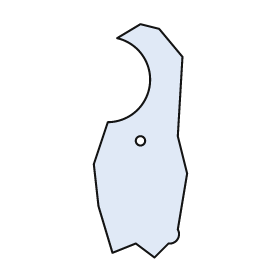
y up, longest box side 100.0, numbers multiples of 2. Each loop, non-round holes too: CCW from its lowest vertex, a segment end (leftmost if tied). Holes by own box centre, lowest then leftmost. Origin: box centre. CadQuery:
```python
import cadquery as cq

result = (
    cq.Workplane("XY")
    .moveTo(6.0, -50.0)
    .lineTo(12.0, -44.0)
    .threePointArc((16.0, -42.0), (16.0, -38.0))
    .lineTo(20.0, -14.0)
    .lineTo(16.0, 2.0)
    .lineTo(18.0, 36.0)
    .lineTo(8.0, 48.0)
    .lineTo(0.0, 50.0)
    .lineTo(-10.0, 44.0)
    .threePointArc((4.0, 24.0), (-14.0, 8.0))
    .lineTo(-20.0, -10.0)
    .lineTo(-18.0, -28.0)
    .lineTo(-12.0, -48.0)
    .lineTo(-2.0, -44.0)
    .close()
    .moveTo(0.0, 0.0)
    .circle(2.0)
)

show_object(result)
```